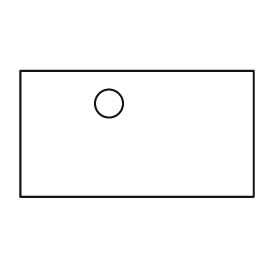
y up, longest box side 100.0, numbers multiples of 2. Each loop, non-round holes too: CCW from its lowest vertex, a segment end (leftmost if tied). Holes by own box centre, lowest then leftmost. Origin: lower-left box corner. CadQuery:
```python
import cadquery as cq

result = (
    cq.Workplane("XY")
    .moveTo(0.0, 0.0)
    .lineTo(100.0, 0.0)
    .lineTo(100.0, 54.0)
    .lineTo(0.0, 54.0)
    .close()
    .moveTo(38.0, 40.0)
    .circle(6.0)
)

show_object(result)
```